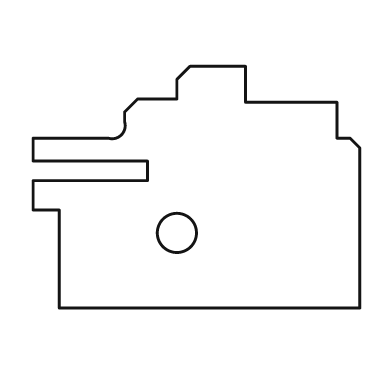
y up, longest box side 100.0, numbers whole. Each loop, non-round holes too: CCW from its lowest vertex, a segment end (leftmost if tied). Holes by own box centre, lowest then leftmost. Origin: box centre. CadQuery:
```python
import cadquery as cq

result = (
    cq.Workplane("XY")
    .moveTo(-42.0, -37.0)
    .lineTo(50.0, -37.0)
    .lineTo(50.0, 12.0)
    .lineTo(47.0, 15.0)
    .lineTo(43.0, 15.0)
    .lineTo(43.0, 26.0)
    .lineTo(15.0, 26.0)
    .lineTo(15.0, 37.0)
    .lineTo(-2.0, 37.0)
    .lineTo(-6.0, 33.0)
    .lineTo(-6.0, 27.0)
    .lineTo(-18.0, 27.0)
    .lineTo(-22.0, 23.0)
    .lineTo(-22.0, 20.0)
    .threePointArc((-23.0, 16.0), (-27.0, 15.0))
    .lineTo(-50.0, 15.0)
    .lineTo(-50.0, 8.0)
    .lineTo(-15.0, 8.0)
    .lineTo(-15.0, 2.0)
    .lineTo(-50.0, 2.0)
    .lineTo(-50.0, -7.0)
    .lineTo(-42.0, -7.0)
    .close()
    .moveTo(-6.0, -14.0)
    .circle(6.0)
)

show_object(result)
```